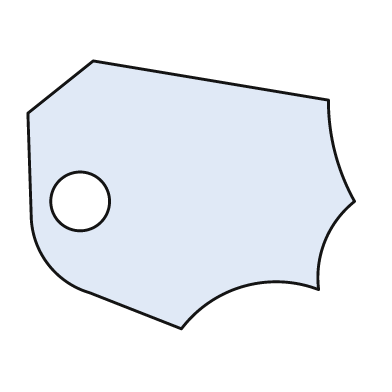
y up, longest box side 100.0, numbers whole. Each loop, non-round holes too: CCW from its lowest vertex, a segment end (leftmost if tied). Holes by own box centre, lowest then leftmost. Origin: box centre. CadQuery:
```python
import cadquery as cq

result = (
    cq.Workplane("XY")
    .moveTo(-3.0, -41.0)
    .threePointArc((16.0, -28.0), (39.0, -29.0))
    .threePointArc((41.0, -14.0), (50.0, -2.0))
    .threePointArc((44.0, 13.0), (42.0, 29.0))
    .lineTo(-30.0, 41.0)
    .lineTo(-50.0, 25.0)
    .lineTo(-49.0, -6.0)
    .threePointArc((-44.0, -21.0), (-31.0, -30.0))
    .close()
    .moveTo(-34.0, -2.0)
    .circle(9.0)
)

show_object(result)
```